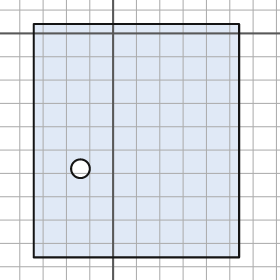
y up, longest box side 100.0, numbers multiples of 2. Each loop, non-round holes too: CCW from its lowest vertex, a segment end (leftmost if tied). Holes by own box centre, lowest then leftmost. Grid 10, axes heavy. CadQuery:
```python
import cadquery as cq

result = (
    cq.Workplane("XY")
    .moveTo(-34.0, -96.0)
    .lineTo(54.0, -96.0)
    .lineTo(54.0, 4.0)
    .lineTo(-34.0, 4.0)
    .close()
    .moveTo(-14.0, -58.0)
    .circle(4.0)
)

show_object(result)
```